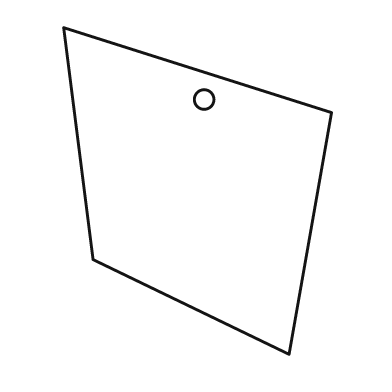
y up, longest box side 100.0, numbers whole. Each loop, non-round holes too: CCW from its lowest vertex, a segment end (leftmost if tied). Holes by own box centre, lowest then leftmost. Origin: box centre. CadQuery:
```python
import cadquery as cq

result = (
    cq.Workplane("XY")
    .moveTo(28.0, -50.0)
    .lineTo(41.0, 24.0)
    .lineTo(-41.0, 50.0)
    .lineTo(-32.0, -21.0)
    .close()
    .moveTo(2.0, 28.0)
    .circle(3.0)
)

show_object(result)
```